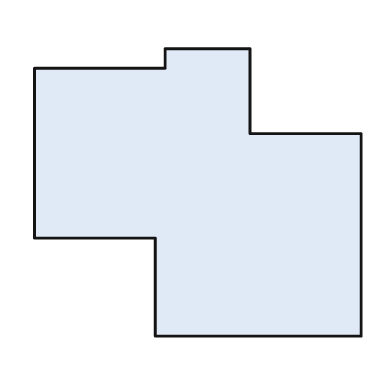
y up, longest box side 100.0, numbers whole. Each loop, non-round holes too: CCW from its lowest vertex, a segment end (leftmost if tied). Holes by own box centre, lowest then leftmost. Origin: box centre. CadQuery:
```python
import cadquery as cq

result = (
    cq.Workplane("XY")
    .moveTo(-13.0, -44.0)
    .lineTo(50.0, -44.0)
    .lineTo(50.0, 18.0)
    .lineTo(16.0, 18.0)
    .lineTo(16.0, 44.0)
    .lineTo(-10.0, 44.0)
    .lineTo(-10.0, 38.0)
    .lineTo(-50.0, 38.0)
    .lineTo(-50.0, -14.0)
    .lineTo(-13.0, -14.0)
    .close()
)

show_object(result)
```